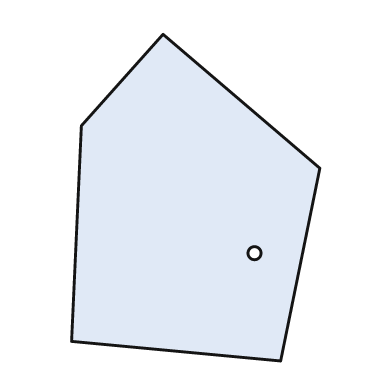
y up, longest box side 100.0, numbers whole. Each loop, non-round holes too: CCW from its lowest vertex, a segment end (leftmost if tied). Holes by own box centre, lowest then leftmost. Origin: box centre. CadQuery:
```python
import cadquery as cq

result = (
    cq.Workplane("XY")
    .moveTo(26.0, -50.0)
    .lineTo(38.0, 9.0)
    .lineTo(-10.0, 50.0)
    .lineTo(-35.0, 22.0)
    .lineTo(-38.0, -44.0)
    .close()
    .moveTo(18.0, -17.0)
    .circle(2.0)
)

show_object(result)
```